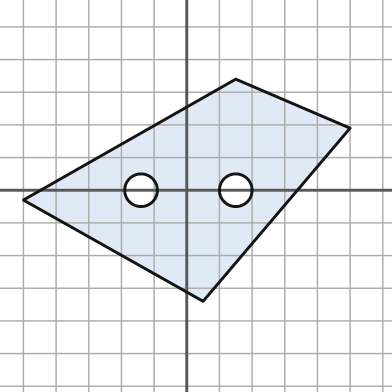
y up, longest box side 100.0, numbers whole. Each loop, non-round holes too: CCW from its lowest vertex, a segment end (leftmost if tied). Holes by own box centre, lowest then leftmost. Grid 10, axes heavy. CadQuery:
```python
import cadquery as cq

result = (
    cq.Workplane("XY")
    .moveTo(5.0, -34.0)
    .lineTo(50.0, 19.0)
    .lineTo(15.0, 34.0)
    .lineTo(-50.0, -3.0)
    .close()
    .moveTo(-14.0, 0.0)
    .circle(5.0)
    .moveTo(15.0, 0.0)
    .circle(5.0)
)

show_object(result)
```